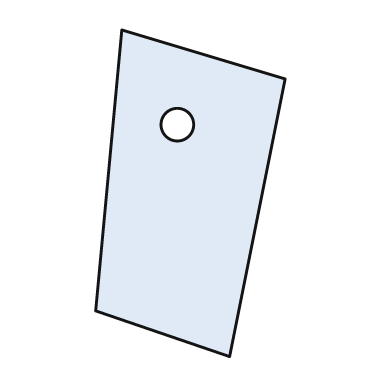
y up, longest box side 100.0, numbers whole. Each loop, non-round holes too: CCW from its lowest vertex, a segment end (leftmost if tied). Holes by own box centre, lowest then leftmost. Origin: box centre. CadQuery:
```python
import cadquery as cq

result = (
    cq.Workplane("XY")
    .moveTo(12.0, -50.0)
    .lineTo(29.0, 35.0)
    .lineTo(-21.0, 50.0)
    .lineTo(-29.0, -36.0)
    .close()
    .moveTo(-4.0, 21.0)
    .circle(5.0)
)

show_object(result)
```